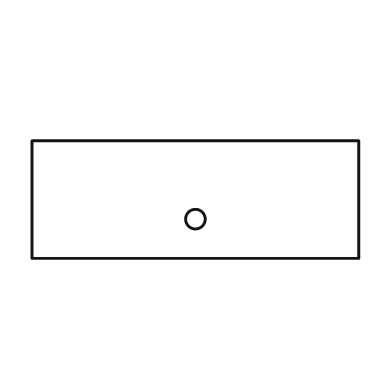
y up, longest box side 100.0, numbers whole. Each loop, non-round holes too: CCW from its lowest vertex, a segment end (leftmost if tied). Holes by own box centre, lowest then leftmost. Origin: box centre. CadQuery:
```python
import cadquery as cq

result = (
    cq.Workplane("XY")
    .moveTo(-50.0, -18.0)
    .lineTo(50.0, -18.0)
    .lineTo(50.0, 18.0)
    .lineTo(-50.0, 18.0)
    .close()
    .moveTo(0.0, -6.0)
    .circle(3.0)
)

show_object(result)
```